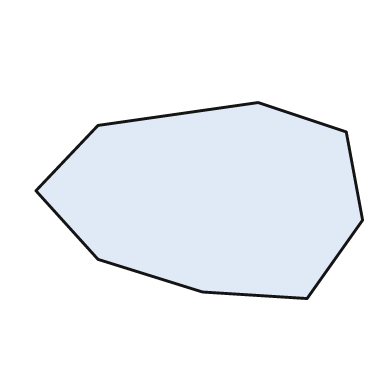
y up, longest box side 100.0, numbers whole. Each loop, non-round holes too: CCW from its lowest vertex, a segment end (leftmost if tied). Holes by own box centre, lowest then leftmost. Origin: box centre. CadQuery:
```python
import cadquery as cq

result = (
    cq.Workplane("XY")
    .moveTo(33.0, -30.0)
    .lineTo(50.0, -6.0)
    .lineTo(45.0, 21.0)
    .lineTo(18.0, 30.0)
    .lineTo(-31.0, 23.0)
    .lineTo(-50.0, 3.0)
    .lineTo(-31.0, -18.0)
    .lineTo(1.0, -28.0)
    .close()
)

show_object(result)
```